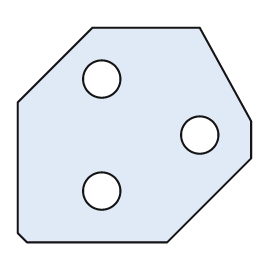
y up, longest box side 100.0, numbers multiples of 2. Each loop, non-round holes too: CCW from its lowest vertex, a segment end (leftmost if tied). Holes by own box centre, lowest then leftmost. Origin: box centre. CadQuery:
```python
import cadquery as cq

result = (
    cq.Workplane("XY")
    .moveTo(-46.0, -46.0)
    .lineTo(14.0, -46.0)
    .lineTo(50.0, -10.0)
    .lineTo(50.0, 6.0)
    .lineTo(28.0, 46.0)
    .lineTo(-18.0, 46.0)
    .lineTo(-50.0, 14.0)
    .lineTo(-50.0, -42.0)
    .close()
    .moveTo(-14.0, -24.0)
    .circle(8.0)
    .moveTo(28.0, 0.0)
    .circle(8.0)
    .moveTo(-14.0, 24.0)
    .circle(8.0)
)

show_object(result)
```